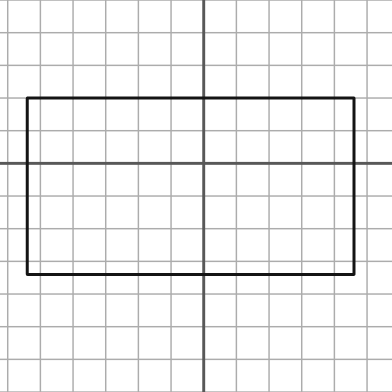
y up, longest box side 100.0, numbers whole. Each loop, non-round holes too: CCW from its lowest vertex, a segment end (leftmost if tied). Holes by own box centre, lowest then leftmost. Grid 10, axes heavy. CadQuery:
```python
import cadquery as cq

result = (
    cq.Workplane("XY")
    .moveTo(-54.0, -34.0)
    .lineTo(46.0, -34.0)
    .lineTo(46.0, 20.0)
    .lineTo(-54.0, 20.0)
    .close()
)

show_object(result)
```